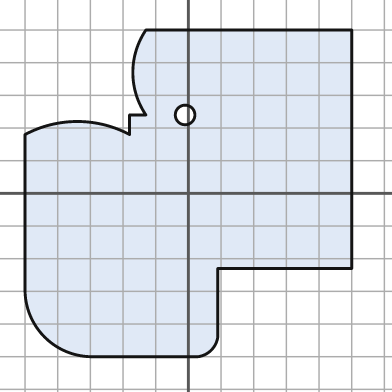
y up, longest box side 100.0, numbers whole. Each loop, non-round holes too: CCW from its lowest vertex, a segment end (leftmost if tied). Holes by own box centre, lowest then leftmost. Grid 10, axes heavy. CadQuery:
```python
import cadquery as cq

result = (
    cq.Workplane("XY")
    .moveTo(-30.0, -50.0)
    .lineTo(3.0, -50.0)
    .threePointArc((7.0, -48.0), (9.0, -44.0))
    .lineTo(9.0, -23.0)
    .lineTo(50.0, -23.0)
    .lineTo(50.0, 50.0)
    .lineTo(-13.0, 50.0)
    .threePointArc((-17.0, 37.0), (-13.0, 24.0))
    .lineTo(-18.0, 24.0)
    .lineTo(-18.0, 18.0)
    .threePointArc((-34.0, 22.0), (-50.0, 18.0))
    .lineTo(-50.0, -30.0)
    .threePointArc((-44.0, -44.0), (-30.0, -50.0))
    .close()
    .moveTo(-1.0, 24.0)
    .circle(3.0)
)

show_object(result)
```